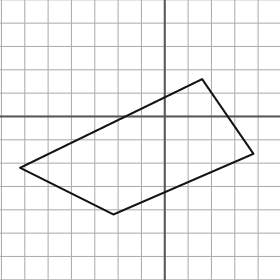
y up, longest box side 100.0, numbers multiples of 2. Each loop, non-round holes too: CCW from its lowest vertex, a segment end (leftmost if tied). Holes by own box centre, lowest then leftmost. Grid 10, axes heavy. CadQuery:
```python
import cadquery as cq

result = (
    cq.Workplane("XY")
    .moveTo(-22.0, -42.0)
    .lineTo(38.0, -16.0)
    .lineTo(16.0, 16.0)
    .lineTo(-62.0, -22.0)
    .close()
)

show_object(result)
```